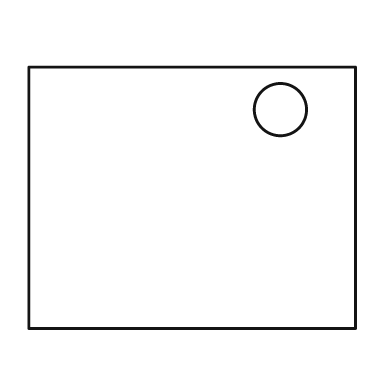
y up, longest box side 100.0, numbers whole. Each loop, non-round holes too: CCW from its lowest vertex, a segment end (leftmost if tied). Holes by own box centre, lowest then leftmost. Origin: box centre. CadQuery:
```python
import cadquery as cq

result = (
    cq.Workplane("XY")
    .moveTo(-50.0, -40.0)
    .lineTo(50.0, -40.0)
    .lineTo(50.0, 40.0)
    .lineTo(-50.0, 40.0)
    .close()
    .moveTo(27.0, 27.0)
    .circle(8.0)
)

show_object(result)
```